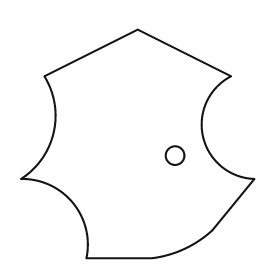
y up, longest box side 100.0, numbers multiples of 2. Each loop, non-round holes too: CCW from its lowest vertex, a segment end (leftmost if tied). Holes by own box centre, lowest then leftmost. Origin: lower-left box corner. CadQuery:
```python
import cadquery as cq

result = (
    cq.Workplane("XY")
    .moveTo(28.0, 0.0)
    .lineTo(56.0, 0.0)
    .threePointArc((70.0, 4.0), (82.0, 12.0))
    .lineTo(100.0, 34.0)
    .threePointArc((78.0, 52.0), (90.0, 78.0))
    .lineTo(50.0, 98.0)
    .lineTo(10.0, 78.0)
    .threePointArc((14.0, 54.0), (0.0, 34.0))
    .threePointArc((22.0, 24.0), (28.0, 0.0))
    .close()
    .moveTo(66.0, 44.0)
    .circle(4.0)
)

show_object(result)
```